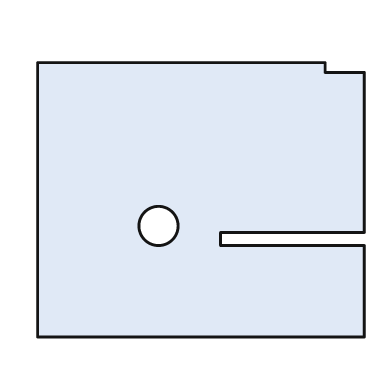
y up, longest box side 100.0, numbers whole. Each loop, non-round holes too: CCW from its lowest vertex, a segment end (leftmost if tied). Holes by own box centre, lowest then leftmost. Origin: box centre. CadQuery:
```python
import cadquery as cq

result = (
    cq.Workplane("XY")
    .moveTo(-50.0, -42.0)
    .lineTo(50.0, -42.0)
    .lineTo(50.0, -14.0)
    .lineTo(6.0, -14.0)
    .lineTo(6.0, -10.0)
    .lineTo(50.0, -10.0)
    .lineTo(50.0, 39.0)
    .lineTo(38.0, 39.0)
    .lineTo(38.0, 42.0)
    .lineTo(-50.0, 42.0)
    .close()
    .moveTo(-13.0, -8.0)
    .circle(6.0)
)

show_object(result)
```